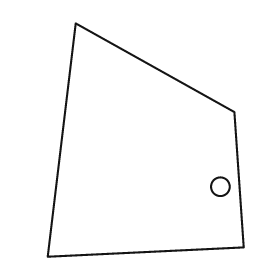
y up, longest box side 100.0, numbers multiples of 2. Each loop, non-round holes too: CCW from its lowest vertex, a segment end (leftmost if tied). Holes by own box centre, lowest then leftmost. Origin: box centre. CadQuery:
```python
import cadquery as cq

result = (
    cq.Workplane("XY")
    .moveTo(-42.0, -50.0)
    .lineTo(42.0, -46.0)
    .lineTo(38.0, 12.0)
    .lineTo(-30.0, 50.0)
    .close()
    .moveTo(32.0, -20.0)
    .circle(4.0)
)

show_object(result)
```